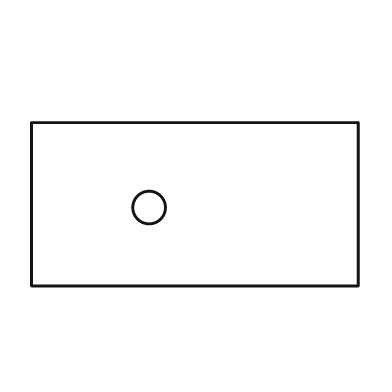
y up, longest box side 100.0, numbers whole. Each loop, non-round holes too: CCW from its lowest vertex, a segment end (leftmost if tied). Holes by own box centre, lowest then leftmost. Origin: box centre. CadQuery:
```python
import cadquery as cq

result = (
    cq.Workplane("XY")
    .moveTo(-50.0, -25.0)
    .lineTo(50.0, -25.0)
    .lineTo(50.0, 25.0)
    .lineTo(-50.0, 25.0)
    .close()
    .moveTo(-14.0, -1.0)
    .circle(5.0)
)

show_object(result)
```